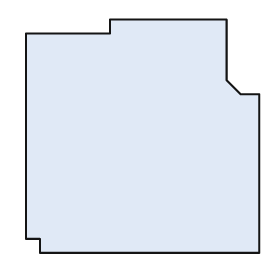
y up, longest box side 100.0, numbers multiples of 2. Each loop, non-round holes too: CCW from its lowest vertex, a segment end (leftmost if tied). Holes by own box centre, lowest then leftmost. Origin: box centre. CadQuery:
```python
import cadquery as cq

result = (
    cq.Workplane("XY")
    .moveTo(-44.0, -50.0)
    .lineTo(50.0, -50.0)
    .lineTo(50.0, 18.0)
    .lineTo(42.0, 18.0)
    .lineTo(36.0, 24.0)
    .lineTo(36.0, 50.0)
    .lineTo(-14.0, 50.0)
    .lineTo(-14.0, 44.0)
    .lineTo(-50.0, 44.0)
    .lineTo(-50.0, -44.0)
    .lineTo(-44.0, -44.0)
    .close()
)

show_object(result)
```